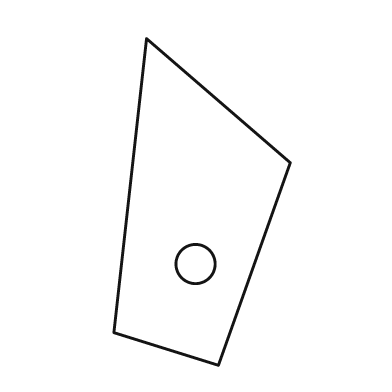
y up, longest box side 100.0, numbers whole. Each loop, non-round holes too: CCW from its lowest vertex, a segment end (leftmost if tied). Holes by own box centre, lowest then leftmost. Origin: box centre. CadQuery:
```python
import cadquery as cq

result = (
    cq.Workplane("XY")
    .moveTo(5.0, -50.0)
    .lineTo(27.0, 12.0)
    .lineTo(-17.0, 50.0)
    .lineTo(-27.0, -40.0)
    .close()
    .moveTo(-2.0, -19.0)
    .circle(6.0)
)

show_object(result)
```